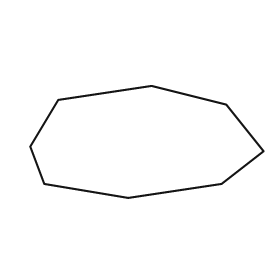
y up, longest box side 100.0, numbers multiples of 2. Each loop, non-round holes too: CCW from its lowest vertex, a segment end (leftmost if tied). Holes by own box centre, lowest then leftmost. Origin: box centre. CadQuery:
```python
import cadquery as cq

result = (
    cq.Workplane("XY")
    .moveTo(-8.0, -24.0)
    .lineTo(32.0, -18.0)
    .lineTo(50.0, -4.0)
    .lineTo(34.0, 16.0)
    .lineTo(2.0, 24.0)
    .lineTo(-38.0, 18.0)
    .lineTo(-50.0, -2.0)
    .lineTo(-44.0, -18.0)
    .close()
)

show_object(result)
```